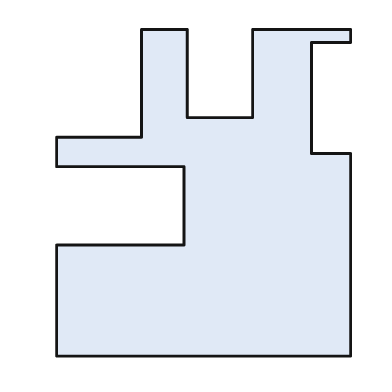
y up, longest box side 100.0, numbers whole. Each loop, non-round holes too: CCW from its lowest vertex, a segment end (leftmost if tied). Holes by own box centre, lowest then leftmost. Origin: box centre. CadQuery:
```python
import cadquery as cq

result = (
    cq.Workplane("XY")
    .moveTo(-45.0, -50.0)
    .lineTo(45.0, -50.0)
    .lineTo(45.0, 12.0)
    .lineTo(33.0, 12.0)
    .lineTo(33.0, 46.0)
    .lineTo(45.0, 46.0)
    .lineTo(45.0, 50.0)
    .lineTo(15.0, 50.0)
    .lineTo(15.0, 23.0)
    .lineTo(-5.0, 23.0)
    .lineTo(-5.0, 50.0)
    .lineTo(-19.0, 50.0)
    .lineTo(-19.0, 17.0)
    .lineTo(-45.0, 17.0)
    .lineTo(-45.0, 8.0)
    .lineTo(-6.0, 8.0)
    .lineTo(-6.0, -16.0)
    .lineTo(-45.0, -16.0)
    .close()
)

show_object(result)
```